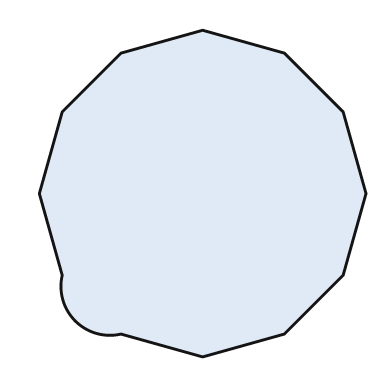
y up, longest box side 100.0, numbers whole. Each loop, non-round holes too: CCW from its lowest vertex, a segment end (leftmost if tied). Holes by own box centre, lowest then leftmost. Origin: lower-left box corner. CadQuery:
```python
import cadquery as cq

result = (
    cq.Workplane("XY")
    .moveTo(50.0, 0.0)
    .lineTo(75.0, 7.0)
    .lineTo(93.0, 25.0)
    .lineTo(100.0, 50.0)
    .lineTo(93.0, 75.0)
    .lineTo(75.0, 93.0)
    .lineTo(50.0, 100.0)
    .lineTo(25.0, 93.0)
    .lineTo(7.0, 75.0)
    .lineTo(0.0, 50.0)
    .lineTo(7.0, 25.0)
    .threePointArc((11.0, 11.0), (25.0, 7.0))
    .close()
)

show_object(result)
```